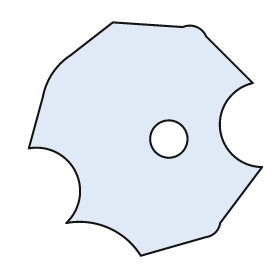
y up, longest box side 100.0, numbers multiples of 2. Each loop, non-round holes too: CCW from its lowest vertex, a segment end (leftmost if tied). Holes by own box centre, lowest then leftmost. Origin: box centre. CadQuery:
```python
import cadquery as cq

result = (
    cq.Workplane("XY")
    .moveTo(-2.0, -50.0)
    .lineTo(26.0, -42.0)
    .threePointArc((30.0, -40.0), (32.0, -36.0))
    .lineTo(50.0, -12.0)
    .threePointArc((32.0, 4.0), (46.0, 24.0))
    .lineTo(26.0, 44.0)
    .threePointArc((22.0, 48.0), (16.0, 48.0))
    .lineTo(-14.0, 50.0)
    .lineTo(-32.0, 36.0)
    .threePointArc((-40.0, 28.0), (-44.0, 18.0))
    .lineTo(-50.0, -4.0)
    .threePointArc((-30.0, -14.0), (-34.0, -36.0))
    .threePointArc((-16.0, -38.0), (-2.0, -50.0))
    .close()
    .moveTo(10.0, 0.0)
    .circle(8.0)
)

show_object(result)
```